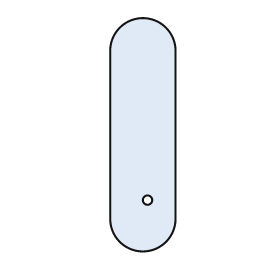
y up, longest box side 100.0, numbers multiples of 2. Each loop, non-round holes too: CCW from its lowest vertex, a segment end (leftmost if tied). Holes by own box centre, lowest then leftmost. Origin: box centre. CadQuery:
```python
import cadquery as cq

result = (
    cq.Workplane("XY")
    .moveTo(-14.0, -36.0)
    .threePointArc((0.0, -50.0), (14.0, -36.0))
    .lineTo(14.0, 36.0)
    .threePointArc((0.0, 50.0), (-14.0, 36.0))
    .close()
    .moveTo(2.0, -28.0)
    .circle(2.0)
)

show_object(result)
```